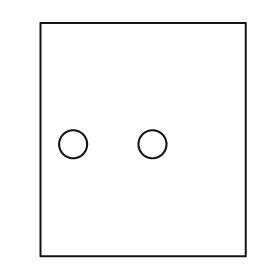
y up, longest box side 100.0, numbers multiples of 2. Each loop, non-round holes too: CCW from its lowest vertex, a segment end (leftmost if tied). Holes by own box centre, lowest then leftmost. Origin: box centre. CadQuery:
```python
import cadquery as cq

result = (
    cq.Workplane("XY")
    .moveTo(-44.0, -50.0)
    .lineTo(44.0, -50.0)
    .lineTo(44.0, 50.0)
    .lineTo(-44.0, 50.0)
    .close()
    .moveTo(-30.0, -2.0)
    .circle(6.0)
    .moveTo(4.0, -2.0)
    .circle(6.0)
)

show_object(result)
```